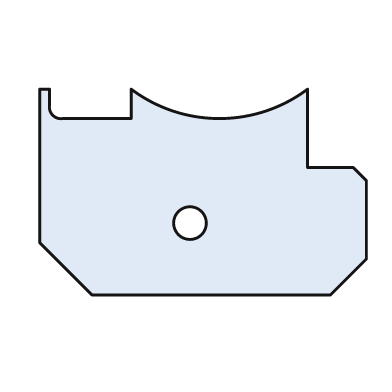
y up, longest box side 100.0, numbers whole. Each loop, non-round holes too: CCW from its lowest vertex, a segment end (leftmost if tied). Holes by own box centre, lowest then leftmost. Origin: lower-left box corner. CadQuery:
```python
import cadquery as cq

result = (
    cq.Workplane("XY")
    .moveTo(16.0, 0.0)
    .lineTo(89.0, 0.0)
    .lineTo(100.0, 11.0)
    .lineTo(100.0, 35.0)
    .lineTo(96.0, 39.0)
    .lineTo(82.0, 39.0)
    .lineTo(82.0, 63.0)
    .threePointArc((55.0, 54.0), (28.0, 63.0))
    .lineTo(28.0, 54.0)
    .lineTo(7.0, 54.0)
    .threePointArc((4.0, 55.0), (3.0, 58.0))
    .lineTo(3.0, 63.0)
    .lineTo(0.0, 63.0)
    .lineTo(0.0, 16.0)
    .close()
    .moveTo(46.0, 22.0)
    .circle(5.0)
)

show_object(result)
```